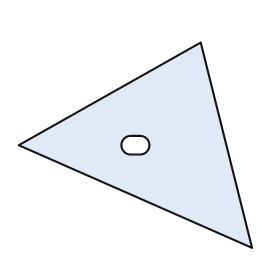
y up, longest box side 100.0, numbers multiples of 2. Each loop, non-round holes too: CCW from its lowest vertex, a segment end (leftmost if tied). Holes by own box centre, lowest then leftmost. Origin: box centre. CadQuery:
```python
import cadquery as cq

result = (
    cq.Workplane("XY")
    .moveTo(50.0, -44.0)
    .lineTo(28.0, 44.0)
    .lineTo(-50.0, 0.0)
    .close()
    .moveTo(-2.0, -4.0)
    .lineTo(2.0, -4.0)
    .threePointArc((6.0, 0.0), (2.0, 4.0))
    .lineTo(-2.0, 4.0)
    .threePointArc((-6.0, 0.0), (-2.0, -4.0))
    .close()
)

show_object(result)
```